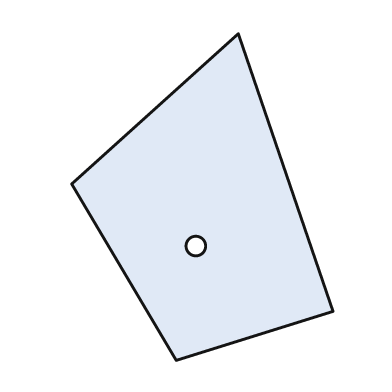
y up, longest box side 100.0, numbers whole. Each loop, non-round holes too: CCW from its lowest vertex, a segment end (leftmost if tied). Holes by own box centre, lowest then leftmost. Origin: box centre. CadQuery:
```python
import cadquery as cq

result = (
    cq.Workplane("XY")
    .moveTo(-8.0, -50.0)
    .lineTo(40.0, -35.0)
    .lineTo(11.0, 50.0)
    .lineTo(-40.0, 4.0)
    .close()
    .moveTo(-2.0, -15.0)
    .circle(3.0)
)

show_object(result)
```